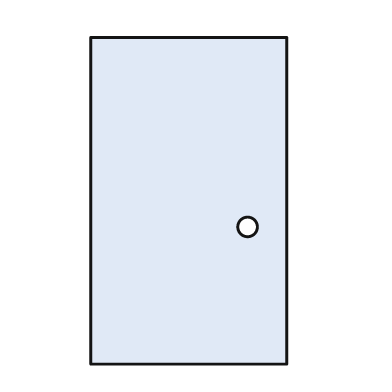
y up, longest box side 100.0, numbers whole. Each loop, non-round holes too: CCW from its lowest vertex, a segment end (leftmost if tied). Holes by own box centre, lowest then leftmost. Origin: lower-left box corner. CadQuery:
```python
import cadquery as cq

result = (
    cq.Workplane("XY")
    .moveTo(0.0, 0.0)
    .lineTo(60.0, 0.0)
    .lineTo(60.0, 100.0)
    .lineTo(0.0, 100.0)
    .close()
    .moveTo(48.0, 42.0)
    .circle(3.0)
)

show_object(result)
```